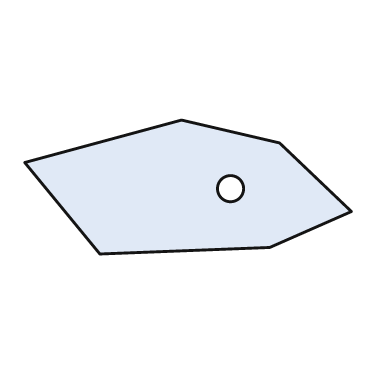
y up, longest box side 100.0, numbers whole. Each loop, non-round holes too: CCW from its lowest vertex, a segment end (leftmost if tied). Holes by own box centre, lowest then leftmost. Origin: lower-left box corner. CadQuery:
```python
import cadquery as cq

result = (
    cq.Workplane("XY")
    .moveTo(23.0, 0.0)
    .lineTo(75.0, 2.0)
    .lineTo(100.0, 13.0)
    .lineTo(78.0, 34.0)
    .lineTo(48.0, 41.0)
    .lineTo(0.0, 28.0)
    .close()
    .moveTo(63.0, 20.0)
    .circle(4.0)
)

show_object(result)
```